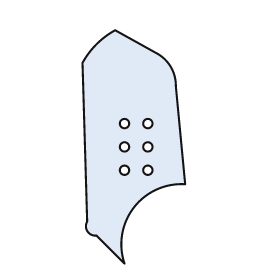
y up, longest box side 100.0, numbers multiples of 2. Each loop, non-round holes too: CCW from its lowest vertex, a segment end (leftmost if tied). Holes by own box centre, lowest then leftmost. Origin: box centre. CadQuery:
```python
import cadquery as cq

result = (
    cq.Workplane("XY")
    .moveTo(-4.0, -50.0)
    .threePointArc((0.0, -26.0), (22.0, -16.0))
    .lineTo(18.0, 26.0)
    .threePointArc((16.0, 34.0), (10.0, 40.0))
    .lineTo(-8.0, 50.0)
    .threePointArc((-16.0, 44.0), (-22.0, 36.0))
    .lineTo(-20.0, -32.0)
    .threePointArc((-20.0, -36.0), (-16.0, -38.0))
    .close()
    .moveTo(-4.0, -10.0)
    .circle(2.0)
    .moveTo(6.0, -10.0)
    .circle(2.0)
    .moveTo(-4.0, 0.0)
    .circle(2.0)
    .moveTo(6.0, 0.0)
    .circle(2.0)
    .moveTo(-4.0, 10.0)
    .circle(2.0)
    .moveTo(6.0, 10.0)
    .circle(2.0)
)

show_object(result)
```